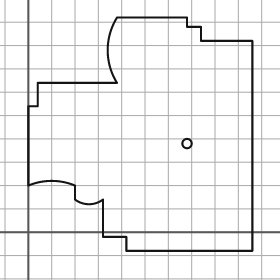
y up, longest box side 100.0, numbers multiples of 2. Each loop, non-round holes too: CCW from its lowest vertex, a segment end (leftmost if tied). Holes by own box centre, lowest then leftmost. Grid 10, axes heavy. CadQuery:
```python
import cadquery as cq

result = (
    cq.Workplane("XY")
    .moveTo(42.0, -8.0)
    .lineTo(96.0, -8.0)
    .lineTo(96.0, 82.0)
    .lineTo(74.0, 82.0)
    .lineTo(74.0, 88.0)
    .lineTo(68.0, 88.0)
    .lineTo(68.0, 92.0)
    .lineTo(38.0, 92.0)
    .threePointArc((34.0, 78.0), (38.0, 64.0))
    .lineTo(4.0, 64.0)
    .lineTo(4.0, 54.0)
    .lineTo(0.0, 54.0)
    .lineTo(0.0, 20.0)
    .threePointArc((10.0, 22.0), (20.0, 20.0))
    .lineTo(20.0, 14.0)
    .threePointArc((26.0, 12.0), (32.0, 14.0))
    .lineTo(32.0, -2.0)
    .lineTo(42.0, -2.0)
    .close()
    .moveTo(68.0, 38.0)
    .circle(2.0)
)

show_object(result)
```